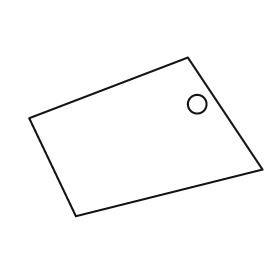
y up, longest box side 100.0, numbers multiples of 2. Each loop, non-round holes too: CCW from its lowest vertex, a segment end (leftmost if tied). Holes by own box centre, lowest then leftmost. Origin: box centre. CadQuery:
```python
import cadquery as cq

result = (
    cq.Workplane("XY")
    .moveTo(-30.0, -34.0)
    .lineTo(50.0, -14.0)
    .lineTo(18.0, 34.0)
    .lineTo(-50.0, 8.0)
    .close()
    .moveTo(22.0, 14.0)
    .circle(4.0)
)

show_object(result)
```